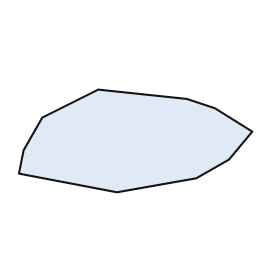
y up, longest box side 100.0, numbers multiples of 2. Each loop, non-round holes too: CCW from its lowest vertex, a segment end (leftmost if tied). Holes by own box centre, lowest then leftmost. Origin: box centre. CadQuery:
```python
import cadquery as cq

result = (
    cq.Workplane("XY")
    .moveTo(-8.0, -22.0)
    .lineTo(26.0, -16.0)
    .lineTo(40.0, -8.0)
    .lineTo(50.0, 4.0)
    .lineTo(34.0, 14.0)
    .lineTo(22.0, 18.0)
    .lineTo(-16.0, 22.0)
    .lineTo(-40.0, 10.0)
    .lineTo(-48.0, -4.0)
    .lineTo(-50.0, -14.0)
    .close()
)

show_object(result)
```